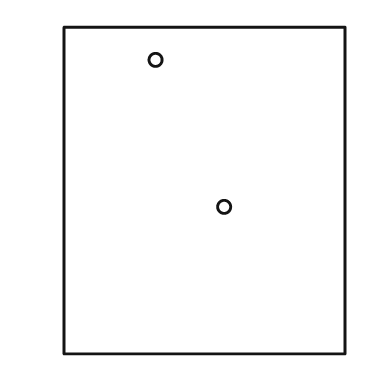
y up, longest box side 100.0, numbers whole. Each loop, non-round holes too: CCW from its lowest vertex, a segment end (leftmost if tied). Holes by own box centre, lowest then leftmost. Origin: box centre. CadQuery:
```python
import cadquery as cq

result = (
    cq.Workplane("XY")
    .moveTo(-43.0, -50.0)
    .lineTo(43.0, -50.0)
    .lineTo(43.0, 50.0)
    .lineTo(-43.0, 50.0)
    .close()
    .moveTo(6.0, -5.0)
    .circle(2.0)
    .moveTo(-15.0, 40.0)
    .circle(2.0)
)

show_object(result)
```